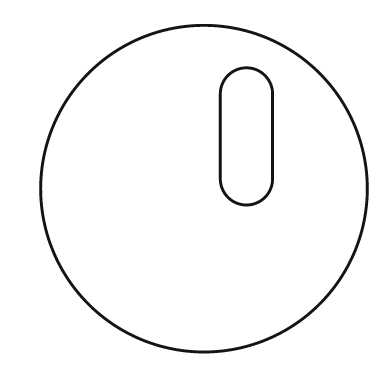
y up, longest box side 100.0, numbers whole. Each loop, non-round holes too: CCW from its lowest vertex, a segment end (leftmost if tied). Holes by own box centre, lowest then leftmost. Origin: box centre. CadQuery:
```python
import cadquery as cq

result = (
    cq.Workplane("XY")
    .moveTo(0.0, 0.0)
    .circle(50.0)
    .moveTo(5.0, 3.0)
    .threePointArc((13.0, -5.0), (21.0, 3.0))
    .lineTo(21.0, 29.0)
    .threePointArc((13.0, 37.0), (5.0, 29.0))
    .close()
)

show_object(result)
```